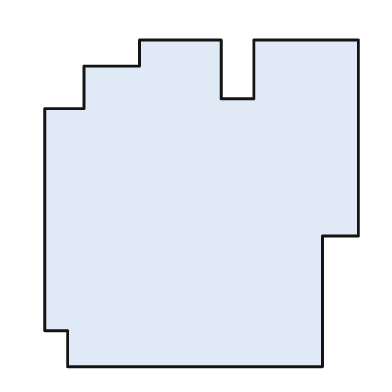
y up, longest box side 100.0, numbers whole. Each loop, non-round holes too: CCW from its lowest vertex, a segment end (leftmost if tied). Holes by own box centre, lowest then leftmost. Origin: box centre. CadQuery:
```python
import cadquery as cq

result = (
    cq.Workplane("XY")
    .moveTo(-41.0, -50.0)
    .lineTo(37.0, -50.0)
    .lineTo(37.0, -10.0)
    .lineTo(48.0, -10.0)
    .lineTo(48.0, 50.0)
    .lineTo(16.0, 50.0)
    .lineTo(16.0, 32.0)
    .lineTo(6.0, 32.0)
    .lineTo(6.0, 50.0)
    .lineTo(-19.0, 50.0)
    .lineTo(-19.0, 42.0)
    .lineTo(-36.0, 42.0)
    .lineTo(-36.0, 29.0)
    .lineTo(-48.0, 29.0)
    .lineTo(-48.0, -39.0)
    .lineTo(-41.0, -39.0)
    .close()
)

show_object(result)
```